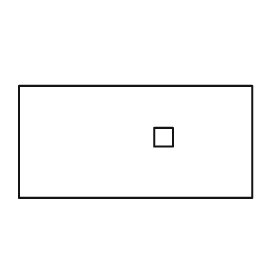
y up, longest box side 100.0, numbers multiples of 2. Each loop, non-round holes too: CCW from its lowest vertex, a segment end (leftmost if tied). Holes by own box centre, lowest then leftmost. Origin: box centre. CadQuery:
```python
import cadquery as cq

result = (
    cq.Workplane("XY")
    .moveTo(-50.0, -24.0)
    .lineTo(50.0, -24.0)
    .lineTo(50.0, 24.0)
    .lineTo(-50.0, 24.0)
    .close()
    .moveTo(8.0, -2.0)
    .lineTo(16.0, -2.0)
    .lineTo(16.0, 6.0)
    .lineTo(8.0, 6.0)
    .close()
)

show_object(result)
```